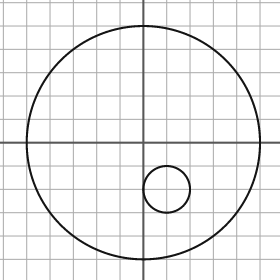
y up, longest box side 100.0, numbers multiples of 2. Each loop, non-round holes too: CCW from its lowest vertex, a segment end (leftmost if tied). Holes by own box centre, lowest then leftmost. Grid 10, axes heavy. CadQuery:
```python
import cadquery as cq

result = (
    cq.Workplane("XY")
    .moveTo(0.0, 0.0)
    .circle(50.0)
    .moveTo(10.0, -20.0)
    .circle(10.0)
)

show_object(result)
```